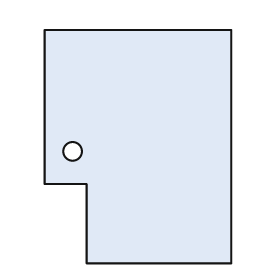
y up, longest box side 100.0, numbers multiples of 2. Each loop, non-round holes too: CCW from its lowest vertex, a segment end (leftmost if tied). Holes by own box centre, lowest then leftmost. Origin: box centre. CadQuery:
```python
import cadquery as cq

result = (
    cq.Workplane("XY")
    .moveTo(-22.0, -50.0)
    .lineTo(40.0, -50.0)
    .lineTo(40.0, 50.0)
    .lineTo(-40.0, 50.0)
    .lineTo(-40.0, -16.0)
    .lineTo(-22.0, -16.0)
    .close()
    .moveTo(-28.0, -2.0)
    .circle(4.0)
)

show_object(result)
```